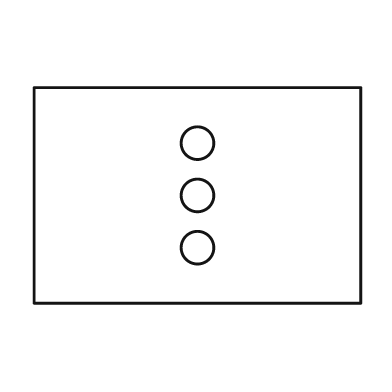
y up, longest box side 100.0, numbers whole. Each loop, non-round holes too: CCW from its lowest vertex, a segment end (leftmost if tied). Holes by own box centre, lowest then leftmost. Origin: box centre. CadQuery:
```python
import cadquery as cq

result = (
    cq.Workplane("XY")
    .moveTo(-50.0, -33.0)
    .lineTo(50.0, -33.0)
    .lineTo(50.0, 33.0)
    .lineTo(-50.0, 33.0)
    .close()
    .moveTo(0.0, -16.0)
    .circle(5.0)
    .moveTo(0.0, 0.0)
    .circle(5.0)
    .moveTo(0.0, 16.0)
    .circle(5.0)
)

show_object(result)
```